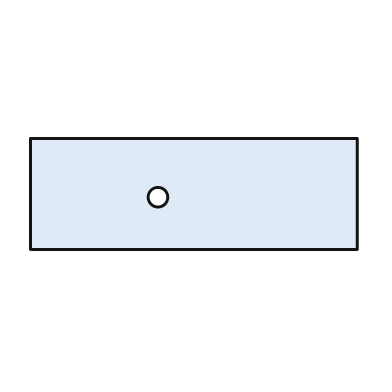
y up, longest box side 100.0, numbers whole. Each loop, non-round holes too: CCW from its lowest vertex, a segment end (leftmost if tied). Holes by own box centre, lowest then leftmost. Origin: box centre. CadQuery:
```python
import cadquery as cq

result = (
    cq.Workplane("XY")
    .moveTo(-50.0, -17.0)
    .lineTo(50.0, -17.0)
    .lineTo(50.0, 17.0)
    .lineTo(-50.0, 17.0)
    .close()
    .moveTo(-11.0, -1.0)
    .circle(3.0)
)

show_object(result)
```